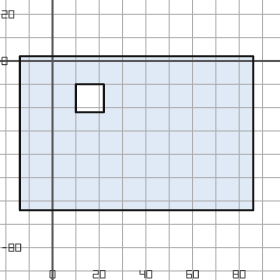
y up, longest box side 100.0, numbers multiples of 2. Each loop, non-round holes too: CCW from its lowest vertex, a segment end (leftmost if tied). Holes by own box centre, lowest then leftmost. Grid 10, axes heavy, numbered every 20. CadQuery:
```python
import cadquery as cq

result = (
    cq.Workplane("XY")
    .moveTo(-14.0, -64.0)
    .lineTo(86.0, -64.0)
    .lineTo(86.0, 2.0)
    .lineTo(-14.0, 2.0)
    .close()
    .moveTo(10.0, -22.0)
    .lineTo(22.0, -22.0)
    .lineTo(22.0, -10.0)
    .lineTo(10.0, -10.0)
    .close()
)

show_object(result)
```